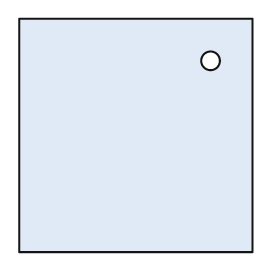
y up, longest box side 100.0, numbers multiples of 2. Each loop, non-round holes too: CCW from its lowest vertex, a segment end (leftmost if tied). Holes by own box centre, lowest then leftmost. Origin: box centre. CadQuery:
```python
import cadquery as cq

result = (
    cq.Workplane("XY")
    .moveTo(-50.0, -50.0)
    .lineTo(50.0, -50.0)
    .lineTo(50.0, 50.0)
    .lineTo(-50.0, 50.0)
    .close()
    .moveTo(32.0, 32.0)
    .circle(4.0)
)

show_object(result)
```